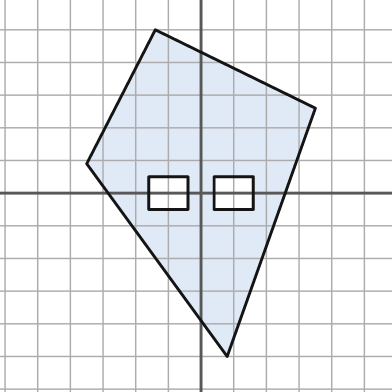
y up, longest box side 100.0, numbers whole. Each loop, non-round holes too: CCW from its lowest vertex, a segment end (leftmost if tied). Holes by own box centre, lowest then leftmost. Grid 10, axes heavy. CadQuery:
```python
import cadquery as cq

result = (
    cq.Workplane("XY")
    .moveTo(8.0, -50.0)
    .lineTo(35.0, 26.0)
    .lineTo(-14.0, 50.0)
    .lineTo(-35.0, 9.0)
    .close()
    .moveTo(-16.0, -5.0)
    .lineTo(-4.0, -5.0)
    .lineTo(-4.0, 5.0)
    .lineTo(-16.0, 5.0)
    .close()
    .moveTo(4.0, -5.0)
    .lineTo(16.0, -5.0)
    .lineTo(16.0, 5.0)
    .lineTo(4.0, 5.0)
    .close()
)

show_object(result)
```